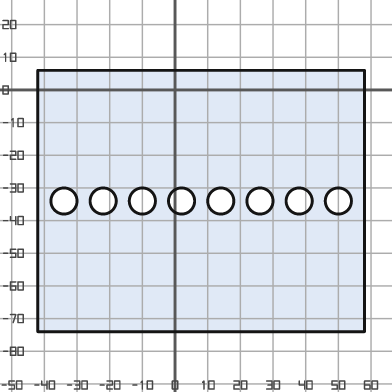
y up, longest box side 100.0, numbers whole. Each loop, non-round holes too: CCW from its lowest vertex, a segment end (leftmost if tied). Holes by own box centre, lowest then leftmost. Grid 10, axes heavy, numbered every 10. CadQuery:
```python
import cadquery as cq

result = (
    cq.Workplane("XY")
    .moveTo(-42.0, -74.0)
    .lineTo(58.0, -74.0)
    .lineTo(58.0, 6.0)
    .lineTo(-42.0, 6.0)
    .close()
    .moveTo(-34.0, -34.0)
    .circle(4.0)
    .moveTo(-22.0, -34.0)
    .circle(4.0)
    .moveTo(-10.0, -34.0)
    .circle(4.0)
    .moveTo(2.0, -34.0)
    .circle(4.0)
    .moveTo(14.0, -34.0)
    .circle(4.0)
    .moveTo(26.0, -34.0)
    .circle(4.0)
    .moveTo(38.0, -34.0)
    .circle(4.0)
    .moveTo(50.0, -34.0)
    .circle(4.0)
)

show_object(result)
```